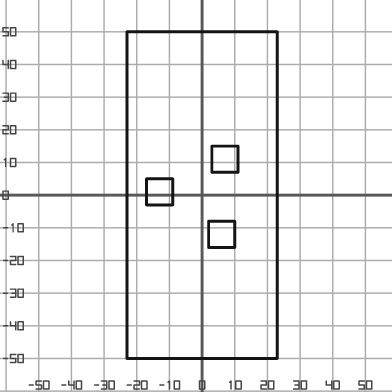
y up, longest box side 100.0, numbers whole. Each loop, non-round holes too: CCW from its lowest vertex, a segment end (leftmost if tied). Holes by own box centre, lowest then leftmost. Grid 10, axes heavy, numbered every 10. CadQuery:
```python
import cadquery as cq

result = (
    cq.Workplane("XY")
    .moveTo(-23.0, -50.0)
    .lineTo(23.0, -50.0)
    .lineTo(23.0, 50.0)
    .lineTo(-23.0, 50.0)
    .close()
    .moveTo(2.0, -16.0)
    .lineTo(10.0, -16.0)
    .lineTo(10.0, -8.0)
    .lineTo(2.0, -8.0)
    .close()
    .moveTo(-17.0, -3.0)
    .lineTo(-9.0, -3.0)
    .lineTo(-9.0, 5.0)
    .lineTo(-17.0, 5.0)
    .close()
    .moveTo(3.0, 7.0)
    .lineTo(11.0, 7.0)
    .lineTo(11.0, 15.0)
    .lineTo(3.0, 15.0)
    .close()
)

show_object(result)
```